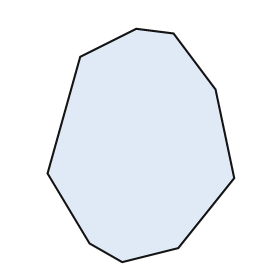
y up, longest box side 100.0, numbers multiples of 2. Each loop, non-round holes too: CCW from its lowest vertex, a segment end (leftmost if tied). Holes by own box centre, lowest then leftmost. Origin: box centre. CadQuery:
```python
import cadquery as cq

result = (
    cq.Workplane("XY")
    .moveTo(-8.0, -50.0)
    .lineTo(16.0, -44.0)
    .lineTo(40.0, -14.0)
    .lineTo(32.0, 24.0)
    .lineTo(14.0, 48.0)
    .lineTo(-2.0, 50.0)
    .lineTo(-26.0, 38.0)
    .lineTo(-40.0, -12.0)
    .lineTo(-22.0, -42.0)
    .close()
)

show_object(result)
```